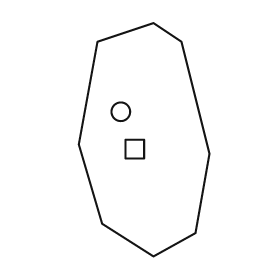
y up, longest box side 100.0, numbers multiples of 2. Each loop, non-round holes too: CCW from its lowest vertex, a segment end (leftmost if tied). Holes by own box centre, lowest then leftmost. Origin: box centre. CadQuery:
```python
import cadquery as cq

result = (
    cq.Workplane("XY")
    .moveTo(4.0, -50.0)
    .lineTo(22.0, -40.0)
    .lineTo(28.0, -6.0)
    .lineTo(16.0, 42.0)
    .lineTo(4.0, 50.0)
    .lineTo(-20.0, 42.0)
    .lineTo(-28.0, -2.0)
    .lineTo(-18.0, -36.0)
    .close()
    .moveTo(-8.0, -8.0)
    .lineTo(0.0, -8.0)
    .lineTo(0.0, 0.0)
    .lineTo(-8.0, 0.0)
    .close()
    .moveTo(-10.0, 12.0)
    .circle(4.0)
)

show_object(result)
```